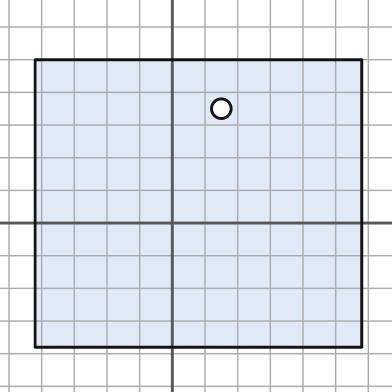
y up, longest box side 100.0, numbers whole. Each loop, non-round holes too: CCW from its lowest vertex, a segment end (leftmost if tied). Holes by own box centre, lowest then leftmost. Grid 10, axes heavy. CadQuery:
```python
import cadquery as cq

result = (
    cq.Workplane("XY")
    .moveTo(-42.0, -38.0)
    .lineTo(58.0, -38.0)
    .lineTo(58.0, 50.0)
    .lineTo(-42.0, 50.0)
    .close()
    .moveTo(15.0, 35.0)
    .circle(3.0)
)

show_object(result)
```